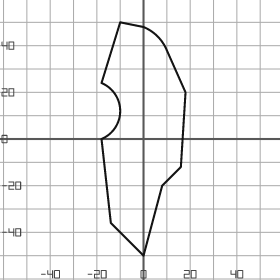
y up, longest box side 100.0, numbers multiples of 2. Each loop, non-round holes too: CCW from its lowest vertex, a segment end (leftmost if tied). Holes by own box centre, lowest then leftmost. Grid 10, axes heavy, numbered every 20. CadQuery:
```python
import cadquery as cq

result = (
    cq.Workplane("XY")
    .moveTo(0.0, -50.0)
    .lineTo(8.0, -20.0)
    .lineTo(16.0, -12.0)
    .lineTo(18.0, 20.0)
    .lineTo(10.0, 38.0)
    .threePointArc((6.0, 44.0), (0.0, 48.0))
    .lineTo(-10.0, 50.0)
    .lineTo(-18.0, 24.0)
    .threePointArc((-10.0, 12.0), (-18.0, 0.0))
    .lineTo(-14.0, -36.0)
    .close()
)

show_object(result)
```